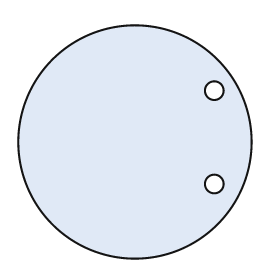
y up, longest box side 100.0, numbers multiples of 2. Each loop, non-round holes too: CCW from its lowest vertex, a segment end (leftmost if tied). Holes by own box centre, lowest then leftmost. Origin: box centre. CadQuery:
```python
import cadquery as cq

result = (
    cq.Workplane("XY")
    .moveTo(0.0, 0.0)
    .circle(50.0)
    .moveTo(34.0, -18.0)
    .circle(4.0)
    .moveTo(34.0, 22.0)
    .circle(4.0)
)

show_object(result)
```